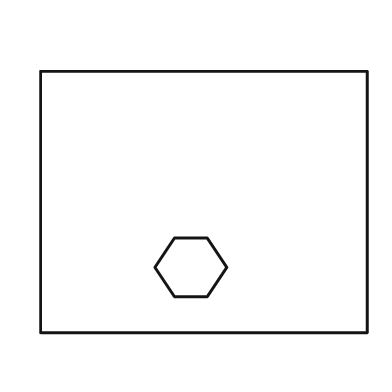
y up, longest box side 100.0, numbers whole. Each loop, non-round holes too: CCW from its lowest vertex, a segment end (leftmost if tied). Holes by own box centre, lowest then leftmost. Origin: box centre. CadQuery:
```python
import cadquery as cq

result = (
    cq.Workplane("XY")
    .moveTo(-50.0, -40.0)
    .lineTo(50.0, -40.0)
    .lineTo(50.0, 40.0)
    .lineTo(-50.0, 40.0)
    .close()
    .moveTo(-9.0, -29.0)
    .lineTo(1.0, -29.0)
    .lineTo(7.0, -20.0)
    .lineTo(1.0, -11.0)
    .lineTo(-9.0, -11.0)
    .lineTo(-15.0, -20.0)
    .close()
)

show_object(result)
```